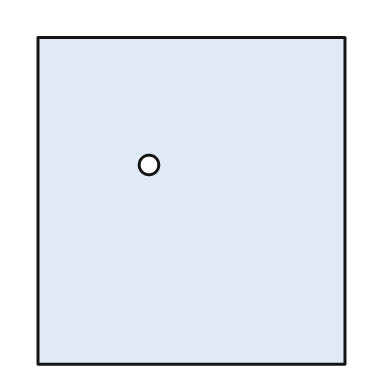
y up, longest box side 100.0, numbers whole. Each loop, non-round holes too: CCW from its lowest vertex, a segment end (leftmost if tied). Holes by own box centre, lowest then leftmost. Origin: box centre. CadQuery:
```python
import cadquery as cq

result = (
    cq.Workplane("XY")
    .moveTo(-47.0, -50.0)
    .lineTo(47.0, -50.0)
    .lineTo(47.0, 50.0)
    .lineTo(-47.0, 50.0)
    .close()
    .moveTo(-13.0, 11.0)
    .circle(3.0)
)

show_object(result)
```